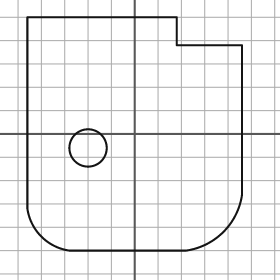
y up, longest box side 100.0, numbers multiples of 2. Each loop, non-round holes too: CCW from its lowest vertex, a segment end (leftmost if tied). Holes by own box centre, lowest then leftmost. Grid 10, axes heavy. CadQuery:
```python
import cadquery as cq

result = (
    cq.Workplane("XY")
    .moveTo(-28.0, -50.0)
    .lineTo(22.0, -50.0)
    .threePointArc((38.0, -42.0), (46.0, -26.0))
    .lineTo(46.0, 38.0)
    .lineTo(18.0, 38.0)
    .lineTo(18.0, 50.0)
    .lineTo(-46.0, 50.0)
    .lineTo(-46.0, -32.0)
    .threePointArc((-40.0, -44.0), (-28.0, -50.0))
    .close()
    .moveTo(-20.0, -6.0)
    .circle(8.0)
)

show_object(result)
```